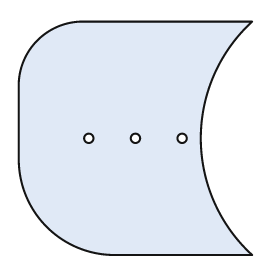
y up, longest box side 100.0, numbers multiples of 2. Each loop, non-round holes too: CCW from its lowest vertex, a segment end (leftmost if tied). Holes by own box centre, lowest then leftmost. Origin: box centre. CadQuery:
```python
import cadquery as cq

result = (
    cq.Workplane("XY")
    .moveTo(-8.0, -50.0)
    .lineTo(50.0, -50.0)
    .threePointArc((28.0, 0.0), (50.0, 50.0))
    .lineTo(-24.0, 50.0)
    .threePointArc((-42.0, 42.0), (-50.0, 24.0))
    .lineTo(-50.0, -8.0)
    .threePointArc((-38.0, -38.0), (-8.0, -50.0))
    .close()
    .moveTo(-20.0, 0.0)
    .circle(2.0)
    .moveTo(0.0, 0.0)
    .circle(2.0)
    .moveTo(20.0, 0.0)
    .circle(2.0)
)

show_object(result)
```